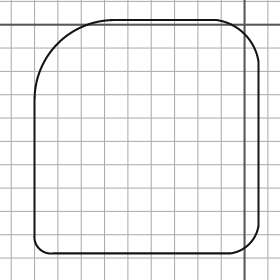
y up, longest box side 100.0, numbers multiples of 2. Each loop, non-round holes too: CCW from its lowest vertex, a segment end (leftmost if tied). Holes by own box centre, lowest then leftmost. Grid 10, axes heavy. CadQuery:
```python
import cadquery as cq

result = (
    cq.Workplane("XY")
    .moveTo(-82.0, -98.0)
    .lineTo(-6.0, -98.0)
    .threePointArc((2.0, -94.0), (6.0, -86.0))
    .lineTo(6.0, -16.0)
    .threePointArc((0.0, -4.0), (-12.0, 2.0))
    .lineTo(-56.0, 2.0)
    .threePointArc((-80.0, -8.0), (-90.0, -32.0))
    .lineTo(-90.0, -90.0)
    .threePointArc((-88.0, -96.0), (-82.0, -98.0))
    .close()
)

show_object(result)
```